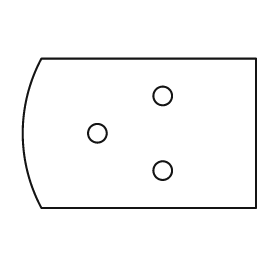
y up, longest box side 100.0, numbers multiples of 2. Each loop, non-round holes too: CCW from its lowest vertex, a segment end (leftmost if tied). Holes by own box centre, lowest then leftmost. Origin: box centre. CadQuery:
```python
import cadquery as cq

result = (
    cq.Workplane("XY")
    .moveTo(-42.0, -32.0)
    .lineTo(50.0, -32.0)
    .lineTo(50.0, 32.0)
    .lineTo(-42.0, 32.0)
    .threePointArc((-50.0, 0.0), (-42.0, -32.0))
    .close()
    .moveTo(10.0, -16.0)
    .circle(4.0)
    .moveTo(-18.0, 0.0)
    .circle(4.0)
    .moveTo(10.0, 16.0)
    .circle(4.0)
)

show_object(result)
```